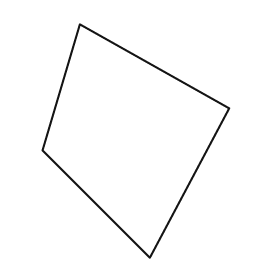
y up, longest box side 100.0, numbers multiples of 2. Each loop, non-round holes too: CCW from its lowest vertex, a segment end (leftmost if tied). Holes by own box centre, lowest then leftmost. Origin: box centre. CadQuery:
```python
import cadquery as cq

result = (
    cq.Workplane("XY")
    .moveTo(6.0, -50.0)
    .lineTo(40.0, 14.0)
    .lineTo(-24.0, 50.0)
    .lineTo(-40.0, -4.0)
    .close()
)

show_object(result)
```